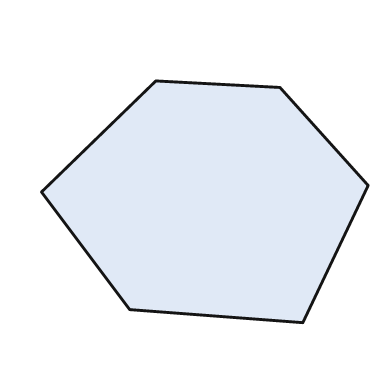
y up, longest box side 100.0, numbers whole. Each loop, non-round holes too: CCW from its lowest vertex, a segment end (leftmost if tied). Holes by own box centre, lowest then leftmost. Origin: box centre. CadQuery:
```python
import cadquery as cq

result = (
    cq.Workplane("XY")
    .moveTo(30.0, -37.0)
    .lineTo(50.0, 5.0)
    .lineTo(23.0, 35.0)
    .lineTo(-15.0, 37.0)
    .lineTo(-50.0, 3.0)
    .lineTo(-23.0, -33.0)
    .close()
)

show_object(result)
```